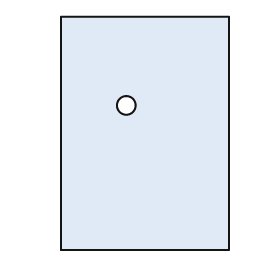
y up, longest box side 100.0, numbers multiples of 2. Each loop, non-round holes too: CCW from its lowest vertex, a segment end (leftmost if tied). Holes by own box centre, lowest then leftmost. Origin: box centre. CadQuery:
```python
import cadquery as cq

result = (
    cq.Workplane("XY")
    .moveTo(-36.0, -50.0)
    .lineTo(36.0, -50.0)
    .lineTo(36.0, 50.0)
    .lineTo(-36.0, 50.0)
    .close()
    .moveTo(-8.0, 12.0)
    .circle(4.0)
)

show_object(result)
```